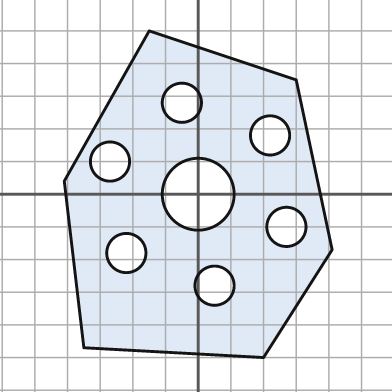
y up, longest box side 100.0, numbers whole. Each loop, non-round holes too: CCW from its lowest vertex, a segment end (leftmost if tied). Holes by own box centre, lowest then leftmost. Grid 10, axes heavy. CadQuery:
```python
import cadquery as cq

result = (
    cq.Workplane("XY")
    .moveTo(20.0, -50.0)
    .lineTo(41.0, -17.0)
    .lineTo(30.0, 35.0)
    .lineTo(-15.0, 50.0)
    .lineTo(-41.0, 4.0)
    .lineTo(-35.0, -47.0)
    .close()
    .moveTo(5.0, -28.0)
    .circle(6.0)
    .moveTo(-22.0, -18.0)
    .circle(6.0)
    .moveTo(27.0, -10.0)
    .circle(6.0)
    .moveTo(0.0, 0.0)
    .circle(11.0)
    .moveTo(-27.0, 10.0)
    .circle(6.0)
    .moveTo(22.0, 18.0)
    .circle(6.0)
    .moveTo(-5.0, 28.0)
    .circle(6.0)
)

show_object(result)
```